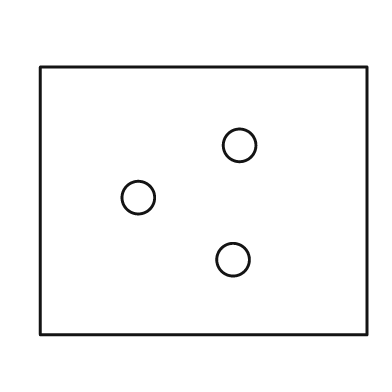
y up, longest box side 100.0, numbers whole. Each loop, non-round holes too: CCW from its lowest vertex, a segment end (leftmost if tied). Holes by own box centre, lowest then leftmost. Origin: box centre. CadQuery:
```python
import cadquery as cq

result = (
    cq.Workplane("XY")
    .moveTo(-50.0, -41.0)
    .lineTo(50.0, -41.0)
    .lineTo(50.0, 41.0)
    .lineTo(-50.0, 41.0)
    .close()
    .moveTo(9.0, -18.0)
    .circle(5.0)
    .moveTo(-20.0, 1.0)
    .circle(5.0)
    .moveTo(11.0, 17.0)
    .circle(5.0)
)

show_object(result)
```